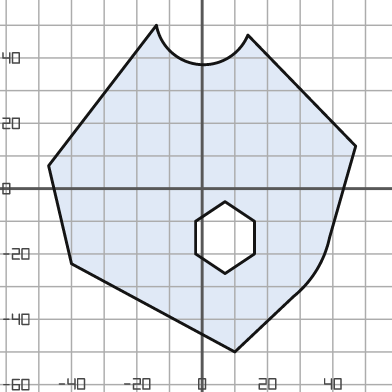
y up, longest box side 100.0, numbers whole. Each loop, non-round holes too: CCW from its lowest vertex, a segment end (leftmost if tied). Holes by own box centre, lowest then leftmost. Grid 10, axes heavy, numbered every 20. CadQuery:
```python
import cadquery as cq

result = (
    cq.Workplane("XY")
    .moveTo(10.0, -50.0)
    .lineTo(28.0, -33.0)
    .threePointArc((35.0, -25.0), (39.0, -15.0))
    .lineTo(47.0, 13.0)
    .lineTo(14.0, 47.0)
    .threePointArc((-1.0, 38.0), (-14.0, 50.0))
    .lineTo(-47.0, 7.0)
    .lineTo(-40.0, -23.0)
    .close()
    .moveTo(7.0, -26.0)
    .lineTo(16.0, -20.0)
    .lineTo(16.0, -10.0)
    .lineTo(7.0, -4.0)
    .lineTo(-2.0, -10.0)
    .lineTo(-2.0, -20.0)
    .close()
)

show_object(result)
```